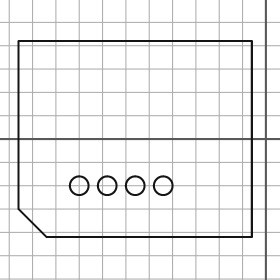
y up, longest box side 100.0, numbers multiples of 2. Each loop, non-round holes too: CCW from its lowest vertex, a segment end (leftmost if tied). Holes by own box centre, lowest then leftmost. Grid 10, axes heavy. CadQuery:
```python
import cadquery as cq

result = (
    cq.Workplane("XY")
    .moveTo(-94.0, -42.0)
    .lineTo(-6.0, -42.0)
    .lineTo(-6.0, 42.0)
    .lineTo(-106.0, 42.0)
    .lineTo(-106.0, -30.0)
    .close()
    .moveTo(-80.0, -20.0)
    .circle(4.0)
    .moveTo(-68.0, -20.0)
    .circle(4.0)
    .moveTo(-56.0, -20.0)
    .circle(4.0)
    .moveTo(-44.0, -20.0)
    .circle(4.0)
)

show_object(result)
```